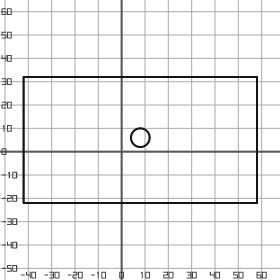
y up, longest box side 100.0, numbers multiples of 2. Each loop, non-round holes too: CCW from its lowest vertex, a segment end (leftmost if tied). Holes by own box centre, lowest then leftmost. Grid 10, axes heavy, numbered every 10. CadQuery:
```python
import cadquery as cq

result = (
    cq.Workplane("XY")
    .moveTo(-42.0, -22.0)
    .lineTo(58.0, -22.0)
    .lineTo(58.0, 32.0)
    .lineTo(-42.0, 32.0)
    .close()
    .moveTo(8.0, 6.0)
    .circle(4.0)
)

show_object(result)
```